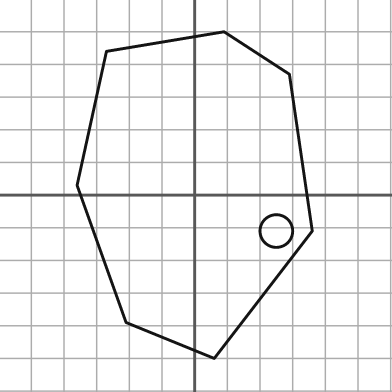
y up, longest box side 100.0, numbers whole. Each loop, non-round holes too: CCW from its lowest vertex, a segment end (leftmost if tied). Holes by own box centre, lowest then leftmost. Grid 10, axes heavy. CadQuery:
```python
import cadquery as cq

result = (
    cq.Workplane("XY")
    .moveTo(6.0, -50.0)
    .lineTo(36.0, -11.0)
    .lineTo(29.0, 37.0)
    .lineTo(9.0, 50.0)
    .lineTo(-27.0, 44.0)
    .lineTo(-36.0, 3.0)
    .lineTo(-21.0, -39.0)
    .close()
    .moveTo(25.0, -11.0)
    .circle(5.0)
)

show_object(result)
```